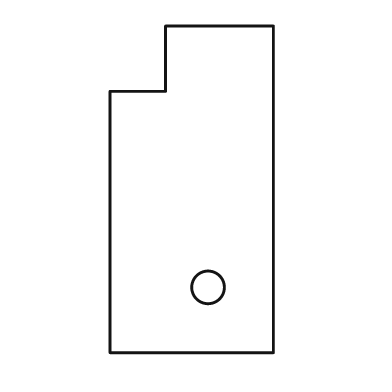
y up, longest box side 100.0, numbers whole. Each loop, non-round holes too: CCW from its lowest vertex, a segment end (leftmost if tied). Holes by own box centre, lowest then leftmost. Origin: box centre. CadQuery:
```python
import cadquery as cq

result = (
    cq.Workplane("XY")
    .moveTo(-25.0, -50.0)
    .lineTo(25.0, -50.0)
    .lineTo(25.0, 50.0)
    .lineTo(-8.0, 50.0)
    .lineTo(-8.0, 30.0)
    .lineTo(-25.0, 30.0)
    .close()
    .moveTo(5.0, -30.0)
    .circle(5.0)
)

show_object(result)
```